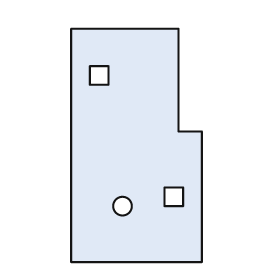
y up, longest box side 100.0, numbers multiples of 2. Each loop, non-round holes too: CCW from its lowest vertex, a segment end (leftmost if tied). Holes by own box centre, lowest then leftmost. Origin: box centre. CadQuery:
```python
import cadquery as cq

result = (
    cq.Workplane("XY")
    .moveTo(-28.0, -50.0)
    .lineTo(28.0, -50.0)
    .lineTo(28.0, 6.0)
    .lineTo(18.0, 6.0)
    .lineTo(18.0, 50.0)
    .lineTo(-28.0, 50.0)
    .close()
    .moveTo(-6.0, -26.0)
    .circle(4.0)
    .moveTo(12.0, -26.0)
    .lineTo(20.0, -26.0)
    .lineTo(20.0, -18.0)
    .lineTo(12.0, -18.0)
    .close()
    .moveTo(-20.0, 26.0)
    .lineTo(-12.0, 26.0)
    .lineTo(-12.0, 34.0)
    .lineTo(-20.0, 34.0)
    .close()
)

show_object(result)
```